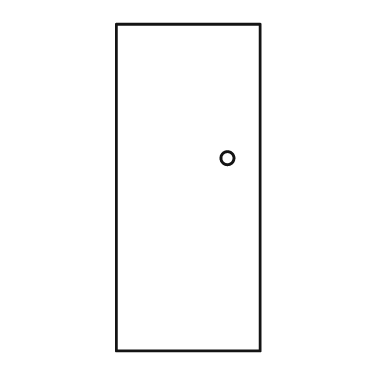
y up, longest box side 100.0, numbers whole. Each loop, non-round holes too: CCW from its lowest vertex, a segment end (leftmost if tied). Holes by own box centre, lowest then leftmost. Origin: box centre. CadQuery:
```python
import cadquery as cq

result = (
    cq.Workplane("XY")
    .moveTo(-22.0, -50.0)
    .lineTo(22.0, -50.0)
    .lineTo(22.0, 50.0)
    .lineTo(-22.0, 50.0)
    .close()
    .moveTo(12.0, 9.0)
    .circle(2.0)
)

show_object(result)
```